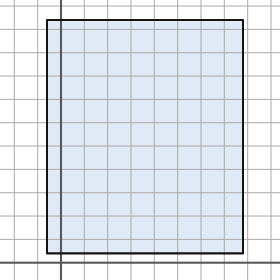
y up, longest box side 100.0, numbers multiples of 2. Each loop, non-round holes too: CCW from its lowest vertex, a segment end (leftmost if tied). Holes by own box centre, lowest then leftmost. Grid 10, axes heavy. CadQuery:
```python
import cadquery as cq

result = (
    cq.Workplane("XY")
    .moveTo(-6.0, 4.0)
    .lineTo(78.0, 4.0)
    .lineTo(78.0, 104.0)
    .lineTo(-6.0, 104.0)
    .close()
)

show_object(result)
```